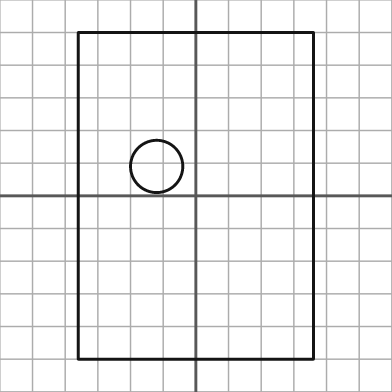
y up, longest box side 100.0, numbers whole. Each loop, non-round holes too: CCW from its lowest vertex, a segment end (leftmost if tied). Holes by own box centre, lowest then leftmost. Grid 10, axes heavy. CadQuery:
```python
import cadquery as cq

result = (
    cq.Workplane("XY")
    .moveTo(-36.0, -50.0)
    .lineTo(36.0, -50.0)
    .lineTo(36.0, 50.0)
    .lineTo(-36.0, 50.0)
    .close()
    .moveTo(-12.0, 9.0)
    .circle(8.0)
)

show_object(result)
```